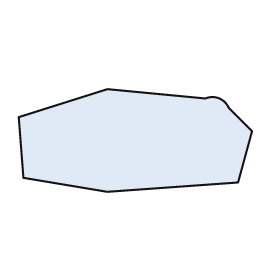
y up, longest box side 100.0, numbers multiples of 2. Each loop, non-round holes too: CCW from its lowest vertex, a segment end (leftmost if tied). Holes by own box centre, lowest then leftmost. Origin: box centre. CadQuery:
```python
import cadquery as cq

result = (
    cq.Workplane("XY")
    .moveTo(-12.0, -22.0)
    .lineTo(44.0, -18.0)
    .lineTo(50.0, 4.0)
    .lineTo(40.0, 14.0)
    .threePointArc((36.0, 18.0), (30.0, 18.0))
    .lineTo(-12.0, 22.0)
    .lineTo(-50.0, 10.0)
    .lineTo(-48.0, -16.0)
    .close()
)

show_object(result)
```